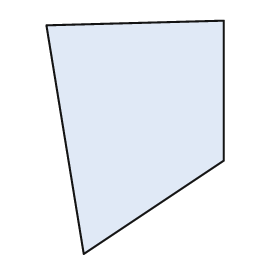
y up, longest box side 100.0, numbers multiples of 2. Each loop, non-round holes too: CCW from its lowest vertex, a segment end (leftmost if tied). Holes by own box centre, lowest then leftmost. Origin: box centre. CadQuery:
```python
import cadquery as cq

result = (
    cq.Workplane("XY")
    .moveTo(-22.0, -50.0)
    .lineTo(38.0, -10.0)
    .lineTo(38.0, 50.0)
    .lineTo(-38.0, 48.0)
    .close()
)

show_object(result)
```